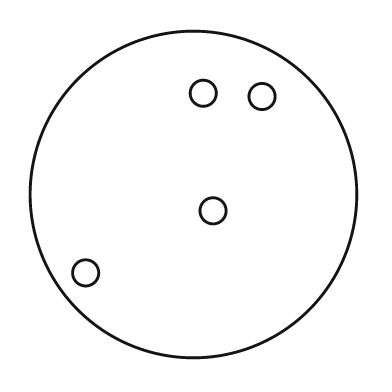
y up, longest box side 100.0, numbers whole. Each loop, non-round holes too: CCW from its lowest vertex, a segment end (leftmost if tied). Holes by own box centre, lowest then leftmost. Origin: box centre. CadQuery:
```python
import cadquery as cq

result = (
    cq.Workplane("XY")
    .moveTo(0.0, 0.0)
    .circle(50.0)
    .moveTo(-33.0, -24.0)
    .circle(4.0)
    .moveTo(6.0, -5.0)
    .circle(4.0)
    .moveTo(21.0, 30.0)
    .circle(4.0)
    .moveTo(3.0, 31.0)
    .circle(4.0)
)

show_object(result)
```